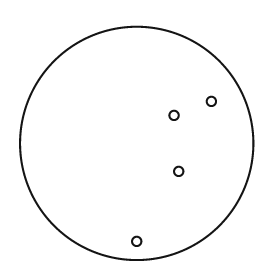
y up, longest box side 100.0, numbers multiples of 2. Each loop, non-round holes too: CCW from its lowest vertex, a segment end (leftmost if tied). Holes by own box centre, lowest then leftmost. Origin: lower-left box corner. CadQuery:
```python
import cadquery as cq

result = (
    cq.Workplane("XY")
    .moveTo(50.0, 50.0)
    .circle(50.0)
    .moveTo(50.0, 8.0)
    .circle(2.0)
    .moveTo(68.0, 38.0)
    .circle(2.0)
    .moveTo(66.0, 62.0)
    .circle(2.0)
    .moveTo(82.0, 68.0)
    .circle(2.0)
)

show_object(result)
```